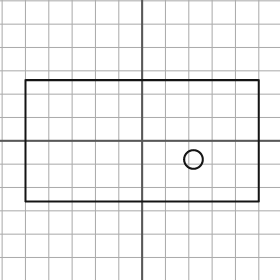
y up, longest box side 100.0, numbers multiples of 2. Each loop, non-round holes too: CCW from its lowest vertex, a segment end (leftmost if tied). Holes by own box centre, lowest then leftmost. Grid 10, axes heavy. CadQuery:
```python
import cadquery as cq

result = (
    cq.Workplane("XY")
    .moveTo(-50.0, -26.0)
    .lineTo(50.0, -26.0)
    .lineTo(50.0, 26.0)
    .lineTo(-50.0, 26.0)
    .close()
    .moveTo(22.0, -8.0)
    .circle(4.0)
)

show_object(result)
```